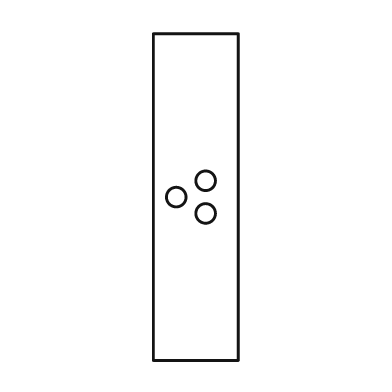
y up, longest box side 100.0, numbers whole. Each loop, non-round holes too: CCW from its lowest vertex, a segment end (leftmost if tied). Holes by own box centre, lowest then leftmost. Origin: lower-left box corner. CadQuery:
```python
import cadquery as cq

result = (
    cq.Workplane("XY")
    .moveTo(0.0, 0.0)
    .lineTo(26.0, 0.0)
    .lineTo(26.0, 100.0)
    .lineTo(0.0, 100.0)
    .close()
    .moveTo(16.0, 45.0)
    .circle(3.0)
    .moveTo(7.0, 50.0)
    .circle(3.0)
    .moveTo(16.0, 55.0)
    .circle(3.0)
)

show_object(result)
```